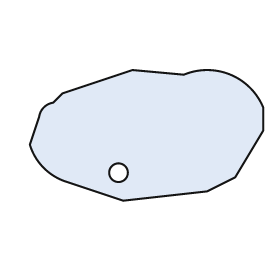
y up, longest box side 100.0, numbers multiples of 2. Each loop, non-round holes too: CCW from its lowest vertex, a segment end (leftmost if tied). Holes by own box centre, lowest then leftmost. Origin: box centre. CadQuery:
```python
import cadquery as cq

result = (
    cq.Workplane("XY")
    .moveTo(-10.0, -28.0)
    .lineTo(26.0, -24.0)
    .lineTo(38.0, -18.0)
    .lineTo(50.0, 2.0)
    .lineTo(50.0, 12.0)
    .threePointArc((36.0, 26.0), (16.0, 26.0))
    .lineTo(-6.0, 28.0)
    .lineTo(-36.0, 18.0)
    .lineTo(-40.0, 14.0)
    .threePointArc((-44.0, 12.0), (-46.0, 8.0))
    .lineTo(-50.0, -4.0)
    .threePointArc((-44.0, -14.0), (-34.0, -20.0))
    .close()
    .moveTo(-12.0, -16.0)
    .circle(4.0)
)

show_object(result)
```